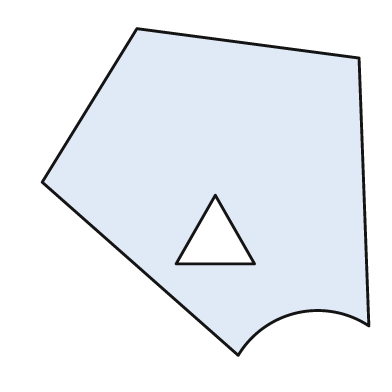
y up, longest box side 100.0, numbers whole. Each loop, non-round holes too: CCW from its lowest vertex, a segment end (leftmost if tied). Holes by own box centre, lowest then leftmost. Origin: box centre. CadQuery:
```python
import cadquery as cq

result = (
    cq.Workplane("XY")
    .moveTo(10.0, -50.0)
    .threePointArc((28.0, -37.0), (50.0, -41.0))
    .lineTo(47.0, 41.0)
    .lineTo(-21.0, 50.0)
    .lineTo(-50.0, 3.0)
    .close()
    .moveTo(-9.0, -22.0)
    .lineTo(15.0, -22.0)
    .lineTo(3.0, -1.0)
    .close()
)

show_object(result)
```